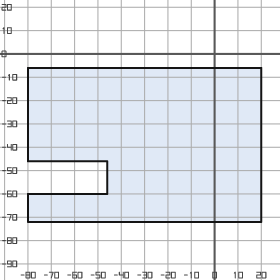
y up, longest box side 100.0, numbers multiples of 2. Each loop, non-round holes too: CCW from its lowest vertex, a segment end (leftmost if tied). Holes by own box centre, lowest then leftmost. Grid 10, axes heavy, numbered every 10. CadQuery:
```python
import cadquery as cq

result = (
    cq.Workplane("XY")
    .moveTo(-80.0, -72.0)
    .lineTo(20.0, -72.0)
    .lineTo(20.0, -6.0)
    .lineTo(-80.0, -6.0)
    .lineTo(-80.0, -46.0)
    .lineTo(-46.0, -46.0)
    .lineTo(-46.0, -60.0)
    .lineTo(-80.0, -60.0)
    .close()
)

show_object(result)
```